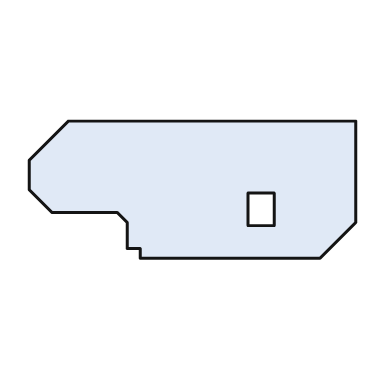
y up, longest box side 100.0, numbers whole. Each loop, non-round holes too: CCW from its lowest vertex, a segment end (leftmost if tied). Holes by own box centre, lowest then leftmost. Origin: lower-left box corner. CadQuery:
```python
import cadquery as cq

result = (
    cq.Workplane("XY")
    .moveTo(34.0, 0.0)
    .lineTo(89.0, 0.0)
    .lineTo(100.0, 11.0)
    .lineTo(100.0, 42.0)
    .lineTo(12.0, 42.0)
    .lineTo(0.0, 30.0)
    .lineTo(0.0, 21.0)
    .lineTo(7.0, 14.0)
    .lineTo(27.0, 14.0)
    .lineTo(30.0, 11.0)
    .lineTo(30.0, 3.0)
    .lineTo(34.0, 3.0)
    .close()
    .moveTo(67.0, 10.0)
    .lineTo(75.0, 10.0)
    .lineTo(75.0, 20.0)
    .lineTo(67.0, 20.0)
    .close()
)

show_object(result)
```